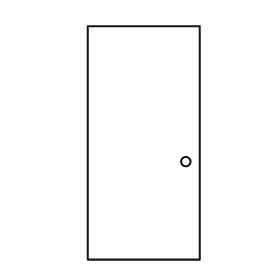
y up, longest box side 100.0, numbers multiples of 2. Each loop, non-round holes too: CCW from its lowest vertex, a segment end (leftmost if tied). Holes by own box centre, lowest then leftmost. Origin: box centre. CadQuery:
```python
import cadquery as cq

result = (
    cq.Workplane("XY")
    .moveTo(-24.0, -50.0)
    .lineTo(24.0, -50.0)
    .lineTo(24.0, 50.0)
    .lineTo(-24.0, 50.0)
    .close()
    .moveTo(18.0, -8.0)
    .circle(2.0)
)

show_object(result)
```